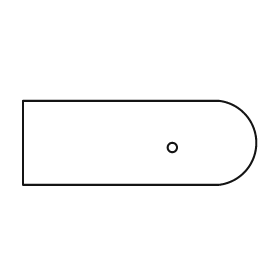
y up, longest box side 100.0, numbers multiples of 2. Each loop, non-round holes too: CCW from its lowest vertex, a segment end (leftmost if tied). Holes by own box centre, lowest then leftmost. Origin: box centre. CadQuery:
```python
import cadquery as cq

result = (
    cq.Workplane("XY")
    .moveTo(-50.0, -18.0)
    .lineTo(34.0, -18.0)
    .threePointArc((50.0, 0.0), (34.0, 18.0))
    .lineTo(-50.0, 18.0)
    .close()
    .moveTo(14.0, -2.0)
    .circle(2.0)
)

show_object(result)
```